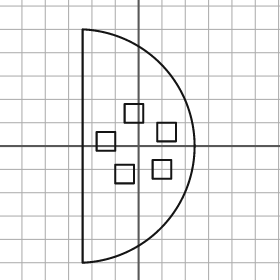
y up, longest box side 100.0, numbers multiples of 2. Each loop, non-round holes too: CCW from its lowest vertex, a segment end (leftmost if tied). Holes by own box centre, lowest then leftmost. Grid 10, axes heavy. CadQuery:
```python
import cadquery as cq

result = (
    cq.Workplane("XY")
    .moveTo(-24.0, -50.0)
    .threePointArc((24.0, 0.0), (-24.0, 50.0))
    .close()
    .moveTo(-10.0, -16.0)
    .lineTo(-2.0, -16.0)
    .lineTo(-2.0, -8.0)
    .lineTo(-10.0, -8.0)
    .close()
    .moveTo(6.0, -14.0)
    .lineTo(14.0, -14.0)
    .lineTo(14.0, -6.0)
    .lineTo(6.0, -6.0)
    .close()
    .moveTo(-18.0, -2.0)
    .lineTo(-10.0, -2.0)
    .lineTo(-10.0, 6.0)
    .lineTo(-18.0, 6.0)
    .close()
    .moveTo(8.0, 2.0)
    .lineTo(16.0, 2.0)
    .lineTo(16.0, 10.0)
    .lineTo(8.0, 10.0)
    .close()
    .moveTo(-6.0, 10.0)
    .lineTo(2.0, 10.0)
    .lineTo(2.0, 18.0)
    .lineTo(-6.0, 18.0)
    .close()
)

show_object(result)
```